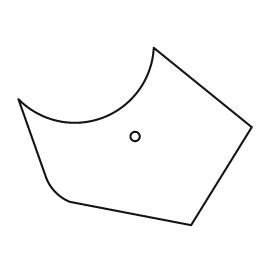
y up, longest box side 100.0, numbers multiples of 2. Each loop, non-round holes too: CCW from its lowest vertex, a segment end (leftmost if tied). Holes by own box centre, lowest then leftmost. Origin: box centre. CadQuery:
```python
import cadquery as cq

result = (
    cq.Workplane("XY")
    .moveTo(24.0, -38.0)
    .lineTo(50.0, 4.0)
    .lineTo(8.0, 38.0)
    .threePointArc((-14.0, 8.0), (-50.0, 16.0))
    .lineTo(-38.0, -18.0)
    .threePointArc((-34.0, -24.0), (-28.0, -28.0))
    .close()
    .moveTo(0.0, 0.0)
    .circle(2.0)
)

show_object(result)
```